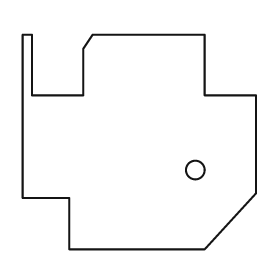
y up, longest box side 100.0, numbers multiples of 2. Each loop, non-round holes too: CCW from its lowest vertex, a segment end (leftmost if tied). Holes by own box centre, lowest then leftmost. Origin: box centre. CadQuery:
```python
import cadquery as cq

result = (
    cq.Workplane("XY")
    .moveTo(-30.0, -46.0)
    .lineTo(28.0, -46.0)
    .lineTo(50.0, -22.0)
    .lineTo(50.0, 20.0)
    .lineTo(28.0, 20.0)
    .lineTo(28.0, 46.0)
    .lineTo(-20.0, 46.0)
    .lineTo(-24.0, 40.0)
    .lineTo(-24.0, 20.0)
    .lineTo(-46.0, 20.0)
    .lineTo(-46.0, 46.0)
    .lineTo(-50.0, 46.0)
    .lineTo(-50.0, -24.0)
    .lineTo(-30.0, -24.0)
    .close()
    .moveTo(24.0, -12.0)
    .circle(4.0)
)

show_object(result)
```